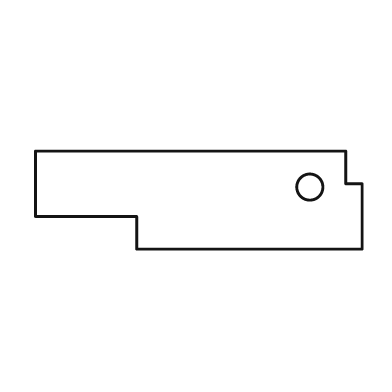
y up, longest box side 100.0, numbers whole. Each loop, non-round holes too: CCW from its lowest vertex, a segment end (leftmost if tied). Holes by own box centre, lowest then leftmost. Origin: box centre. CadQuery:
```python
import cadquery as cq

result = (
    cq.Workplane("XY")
    .moveTo(-19.0, -15.0)
    .lineTo(50.0, -15.0)
    .lineTo(50.0, 5.0)
    .lineTo(45.0, 5.0)
    .lineTo(45.0, 15.0)
    .lineTo(-50.0, 15.0)
    .lineTo(-50.0, -5.0)
    .lineTo(-19.0, -5.0)
    .close()
    .moveTo(34.0, 4.0)
    .circle(4.0)
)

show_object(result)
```